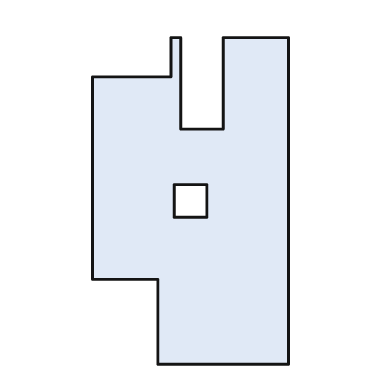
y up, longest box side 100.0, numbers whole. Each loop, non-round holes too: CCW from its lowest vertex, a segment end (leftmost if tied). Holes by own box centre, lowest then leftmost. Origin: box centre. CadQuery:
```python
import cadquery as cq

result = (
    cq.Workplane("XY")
    .moveTo(-10.0, -50.0)
    .lineTo(30.0, -50.0)
    .lineTo(30.0, 50.0)
    .lineTo(10.0, 50.0)
    .lineTo(10.0, 22.0)
    .lineTo(-3.0, 22.0)
    .lineTo(-3.0, 50.0)
    .lineTo(-6.0, 50.0)
    .lineTo(-6.0, 38.0)
    .lineTo(-30.0, 38.0)
    .lineTo(-30.0, -24.0)
    .lineTo(-10.0, -24.0)
    .close()
    .moveTo(-5.0, -5.0)
    .lineTo(5.0, -5.0)
    .lineTo(5.0, 5.0)
    .lineTo(-5.0, 5.0)
    .close()
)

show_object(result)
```